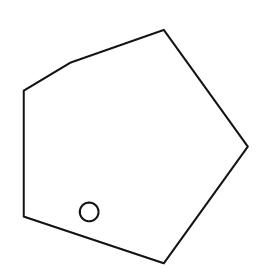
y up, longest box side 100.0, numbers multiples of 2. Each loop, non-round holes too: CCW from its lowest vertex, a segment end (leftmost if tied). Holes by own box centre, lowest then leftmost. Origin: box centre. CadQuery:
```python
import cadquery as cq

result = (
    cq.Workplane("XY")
    .moveTo(12.0, -50.0)
    .lineTo(48.0, 0.0)
    .lineTo(12.0, 50.0)
    .lineTo(-28.0, 36.0)
    .lineTo(-48.0, 24.0)
    .lineTo(-48.0, -30.0)
    .close()
    .moveTo(-20.0, -28.0)
    .circle(4.0)
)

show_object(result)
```